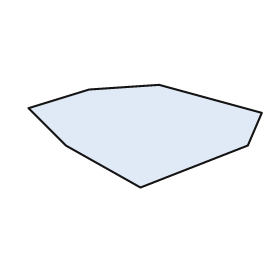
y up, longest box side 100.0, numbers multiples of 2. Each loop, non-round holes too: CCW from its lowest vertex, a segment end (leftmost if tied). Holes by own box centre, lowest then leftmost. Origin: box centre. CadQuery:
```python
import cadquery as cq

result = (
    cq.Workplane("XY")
    .moveTo(-2.0, -22.0)
    .lineTo(44.0, -4.0)
    .lineTo(50.0, 10.0)
    .lineTo(6.0, 22.0)
    .lineTo(-24.0, 20.0)
    .lineTo(-50.0, 12.0)
    .lineTo(-34.0, -4.0)
    .close()
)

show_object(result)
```